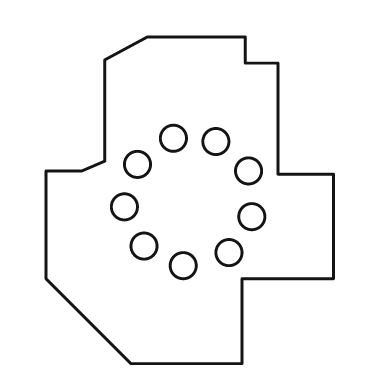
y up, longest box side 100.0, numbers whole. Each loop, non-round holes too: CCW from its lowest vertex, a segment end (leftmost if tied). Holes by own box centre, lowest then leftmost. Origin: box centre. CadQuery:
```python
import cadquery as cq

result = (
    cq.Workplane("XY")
    .moveTo(-18.0, -50.0)
    .lineTo(16.0, -50.0)
    .lineTo(16.0, -24.0)
    .lineTo(44.0, -24.0)
    .lineTo(44.0, 8.0)
    .lineTo(27.0, 8.0)
    .lineTo(27.0, 42.0)
    .lineTo(17.0, 42.0)
    .lineTo(17.0, 50.0)
    .lineTo(-13.0, 50.0)
    .lineTo(-26.0, 43.0)
    .lineTo(-26.0, 12.0)
    .lineTo(-33.0, 9.0)
    .lineTo(-44.0, 9.0)
    .lineTo(-44.0, -24.0)
    .close()
    .moveTo(-2.0, -20.0)
    .circle(4.0)
    .moveTo(12.0, -16.0)
    .circle(4.0)
    .moveTo(-14.0, -14.0)
    .circle(4.0)
    .moveTo(19.0, -5.0)
    .circle(4.0)
    .moveTo(-20.0, -2.0)
    .circle(4.0)
    .moveTo(18.0, 9.0)
    .circle(4.0)
    .moveTo(-16.0, 11.0)
    .circle(4.0)
    .moveTo(8.0, 18.0)
    .circle(4.0)
    .moveTo(-5.0, 19.0)
    .circle(4.0)
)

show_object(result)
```